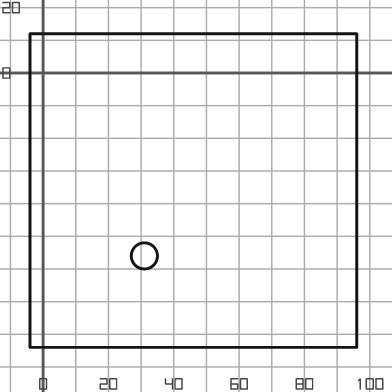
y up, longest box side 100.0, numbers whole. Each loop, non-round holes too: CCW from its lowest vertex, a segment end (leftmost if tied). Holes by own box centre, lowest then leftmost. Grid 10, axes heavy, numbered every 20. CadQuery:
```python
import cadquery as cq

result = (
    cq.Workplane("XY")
    .moveTo(-4.0, -84.0)
    .lineTo(96.0, -84.0)
    .lineTo(96.0, 12.0)
    .lineTo(-4.0, 12.0)
    .close()
    .moveTo(31.0, -56.0)
    .circle(4.0)
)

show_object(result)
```